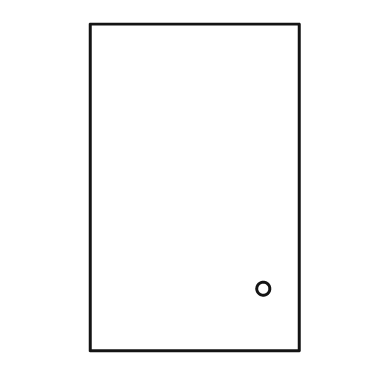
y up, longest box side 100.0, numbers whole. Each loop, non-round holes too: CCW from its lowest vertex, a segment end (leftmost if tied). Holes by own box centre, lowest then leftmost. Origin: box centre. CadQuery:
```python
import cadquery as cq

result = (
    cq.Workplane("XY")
    .moveTo(-32.0, -50.0)
    .lineTo(32.0, -50.0)
    .lineTo(32.0, 50.0)
    .lineTo(-32.0, 50.0)
    .close()
    .moveTo(21.0, -31.0)
    .circle(2.0)
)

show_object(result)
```